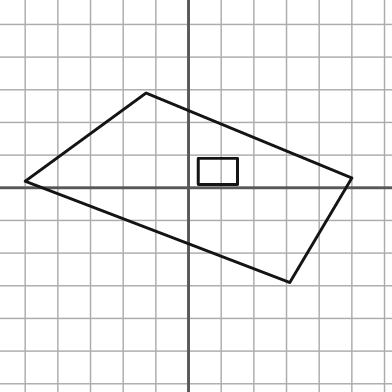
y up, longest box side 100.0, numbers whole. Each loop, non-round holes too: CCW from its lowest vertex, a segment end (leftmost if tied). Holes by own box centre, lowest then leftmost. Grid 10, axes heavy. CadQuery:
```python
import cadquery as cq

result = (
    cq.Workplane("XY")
    .moveTo(31.0, -29.0)
    .lineTo(50.0, 3.0)
    .lineTo(-13.0, 29.0)
    .lineTo(-50.0, 2.0)
    .close()
    .moveTo(3.0, 1.0)
    .lineTo(15.0, 1.0)
    .lineTo(15.0, 9.0)
    .lineTo(3.0, 9.0)
    .close()
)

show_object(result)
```